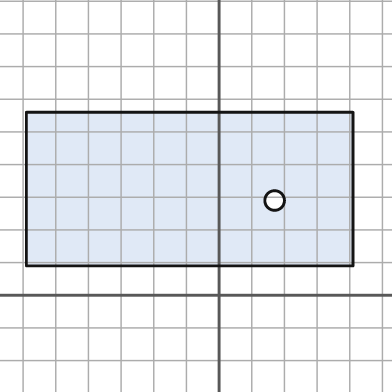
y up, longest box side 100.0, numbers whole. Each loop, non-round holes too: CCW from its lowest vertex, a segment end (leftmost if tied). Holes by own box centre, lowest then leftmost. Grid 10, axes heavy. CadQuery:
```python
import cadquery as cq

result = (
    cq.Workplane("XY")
    .moveTo(-59.0, 9.0)
    .lineTo(41.0, 9.0)
    .lineTo(41.0, 56.0)
    .lineTo(-59.0, 56.0)
    .close()
    .moveTo(17.0, 29.0)
    .circle(3.0)
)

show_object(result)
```